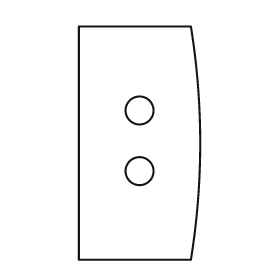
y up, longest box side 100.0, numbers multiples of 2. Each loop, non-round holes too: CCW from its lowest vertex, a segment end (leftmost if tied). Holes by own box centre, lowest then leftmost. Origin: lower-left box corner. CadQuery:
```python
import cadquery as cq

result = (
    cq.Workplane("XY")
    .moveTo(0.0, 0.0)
    .lineTo(48.0, 0.0)
    .threePointArc((52.0, 50.0), (48.0, 100.0))
    .lineTo(0.0, 100.0)
    .close()
    .moveTo(26.0, 38.0)
    .circle(6.0)
    .moveTo(26.0, 64.0)
    .circle(6.0)
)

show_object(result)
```